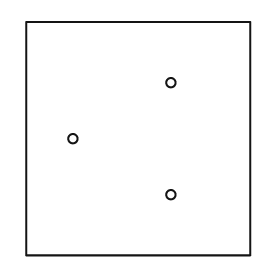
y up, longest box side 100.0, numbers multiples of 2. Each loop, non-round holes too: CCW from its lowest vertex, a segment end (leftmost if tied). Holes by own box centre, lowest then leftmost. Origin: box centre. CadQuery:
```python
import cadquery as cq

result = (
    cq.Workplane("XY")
    .moveTo(-48.0, -50.0)
    .lineTo(48.0, -50.0)
    .lineTo(48.0, 50.0)
    .lineTo(-48.0, 50.0)
    .close()
    .moveTo(14.0, -24.0)
    .circle(2.0)
    .moveTo(-28.0, 0.0)
    .circle(2.0)
    .moveTo(14.0, 24.0)
    .circle(2.0)
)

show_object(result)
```